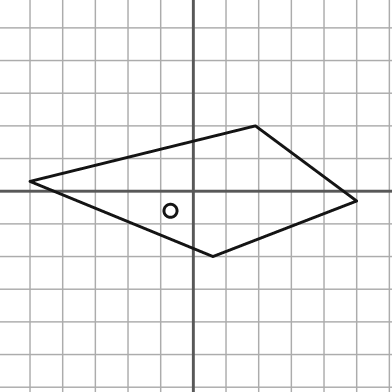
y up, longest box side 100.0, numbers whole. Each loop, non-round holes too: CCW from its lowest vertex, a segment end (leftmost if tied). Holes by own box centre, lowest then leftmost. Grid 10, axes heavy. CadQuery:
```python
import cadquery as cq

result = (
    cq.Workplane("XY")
    .moveTo(6.0, -20.0)
    .lineTo(50.0, -3.0)
    .lineTo(19.0, 20.0)
    .lineTo(-50.0, 3.0)
    .close()
    .moveTo(-7.0, -6.0)
    .circle(2.0)
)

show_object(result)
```